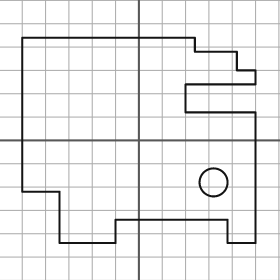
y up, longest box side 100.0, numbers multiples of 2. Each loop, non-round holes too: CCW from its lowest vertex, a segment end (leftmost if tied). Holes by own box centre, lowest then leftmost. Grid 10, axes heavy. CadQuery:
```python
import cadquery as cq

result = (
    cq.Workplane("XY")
    .moveTo(-34.0, -44.0)
    .lineTo(-10.0, -44.0)
    .lineTo(-10.0, -34.0)
    .lineTo(38.0, -34.0)
    .lineTo(38.0, -44.0)
    .lineTo(50.0, -44.0)
    .lineTo(50.0, 12.0)
    .lineTo(20.0, 12.0)
    .lineTo(20.0, 24.0)
    .lineTo(50.0, 24.0)
    .lineTo(50.0, 30.0)
    .lineTo(42.0, 30.0)
    .lineTo(42.0, 38.0)
    .lineTo(24.0, 38.0)
    .lineTo(24.0, 44.0)
    .lineTo(-50.0, 44.0)
    .lineTo(-50.0, -22.0)
    .lineTo(-34.0, -22.0)
    .close()
    .moveTo(32.0, -18.0)
    .circle(6.0)
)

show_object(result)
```